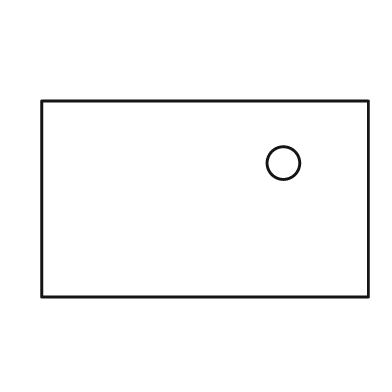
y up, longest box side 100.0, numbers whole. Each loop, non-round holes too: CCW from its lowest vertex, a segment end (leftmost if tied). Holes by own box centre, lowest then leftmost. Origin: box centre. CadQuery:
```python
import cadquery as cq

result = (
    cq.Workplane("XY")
    .moveTo(-50.0, -30.0)
    .lineTo(50.0, -30.0)
    .lineTo(50.0, 30.0)
    .lineTo(-50.0, 30.0)
    .close()
    .moveTo(24.0, 11.0)
    .circle(5.0)
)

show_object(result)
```